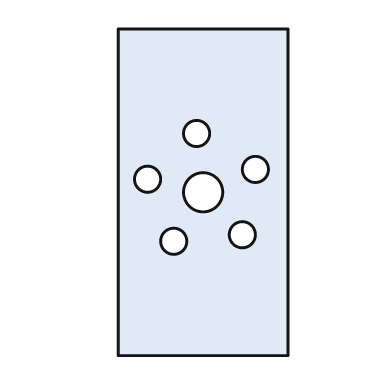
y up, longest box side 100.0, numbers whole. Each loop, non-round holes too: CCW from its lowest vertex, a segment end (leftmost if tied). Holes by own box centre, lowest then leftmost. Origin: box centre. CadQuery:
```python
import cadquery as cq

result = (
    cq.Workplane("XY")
    .moveTo(-26.0, -50.0)
    .lineTo(26.0, -50.0)
    .lineTo(26.0, 50.0)
    .lineTo(-26.0, 50.0)
    .close()
    .moveTo(-9.0, -15.0)
    .circle(4.0)
    .moveTo(12.0, -13.0)
    .circle(4.0)
    .moveTo(0.0, 0.0)
    .circle(6.0)
    .moveTo(-17.0, 4.0)
    .circle(4.0)
    .moveTo(16.0, 7.0)
    .circle(4.0)
    .moveTo(-2.0, 18.0)
    .circle(4.0)
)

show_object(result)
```